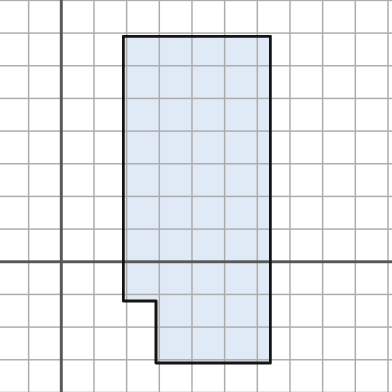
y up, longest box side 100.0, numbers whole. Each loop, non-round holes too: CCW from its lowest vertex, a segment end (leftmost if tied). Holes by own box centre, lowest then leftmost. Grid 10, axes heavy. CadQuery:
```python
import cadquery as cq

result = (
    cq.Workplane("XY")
    .moveTo(29.0, -31.0)
    .lineTo(64.0, -31.0)
    .lineTo(64.0, 69.0)
    .lineTo(19.0, 69.0)
    .lineTo(19.0, -12.0)
    .lineTo(29.0, -12.0)
    .close()
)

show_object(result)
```